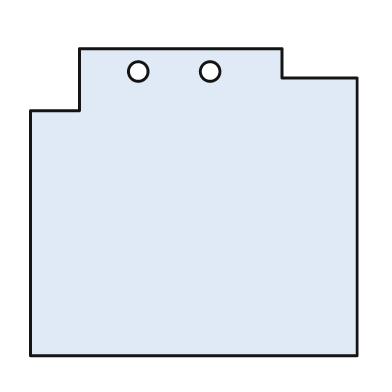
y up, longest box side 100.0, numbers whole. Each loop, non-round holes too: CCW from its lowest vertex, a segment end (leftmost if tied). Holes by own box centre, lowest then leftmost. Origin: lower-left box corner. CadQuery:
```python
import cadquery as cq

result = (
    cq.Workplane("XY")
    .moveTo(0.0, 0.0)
    .lineTo(100.0, 0.0)
    .lineTo(100.0, 85.0)
    .lineTo(77.0, 85.0)
    .lineTo(77.0, 94.0)
    .lineTo(15.0, 94.0)
    .lineTo(15.0, 75.0)
    .lineTo(0.0, 75.0)
    .close()
    .moveTo(33.0, 87.0)
    .circle(3.0)
    .moveTo(55.0, 87.0)
    .circle(3.0)
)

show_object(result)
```